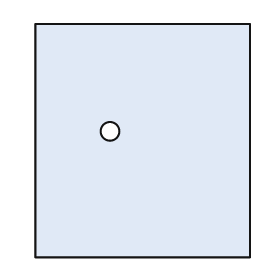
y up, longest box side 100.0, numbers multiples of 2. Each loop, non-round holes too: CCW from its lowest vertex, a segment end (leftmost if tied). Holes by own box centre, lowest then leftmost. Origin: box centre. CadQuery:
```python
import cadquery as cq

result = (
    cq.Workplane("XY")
    .moveTo(-46.0, -50.0)
    .lineTo(46.0, -50.0)
    .lineTo(46.0, 50.0)
    .lineTo(-46.0, 50.0)
    .close()
    .moveTo(-14.0, 4.0)
    .circle(4.0)
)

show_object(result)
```